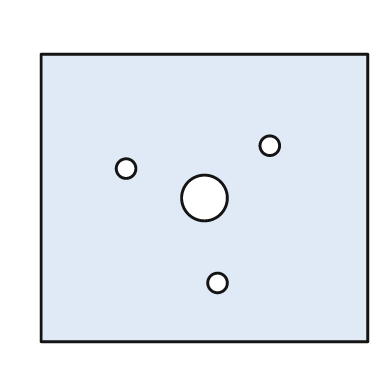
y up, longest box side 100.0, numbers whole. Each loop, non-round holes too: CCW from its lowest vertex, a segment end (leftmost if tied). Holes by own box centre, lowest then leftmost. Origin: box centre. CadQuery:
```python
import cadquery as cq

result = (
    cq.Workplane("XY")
    .moveTo(-50.0, -44.0)
    .lineTo(50.0, -44.0)
    .lineTo(50.0, 44.0)
    .lineTo(-50.0, 44.0)
    .close()
    .moveTo(4.0, -26.0)
    .circle(3.0)
    .moveTo(0.0, 0.0)
    .circle(7.0)
    .moveTo(-24.0, 9.0)
    .circle(3.0)
    .moveTo(20.0, 16.0)
    .circle(3.0)
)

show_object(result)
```